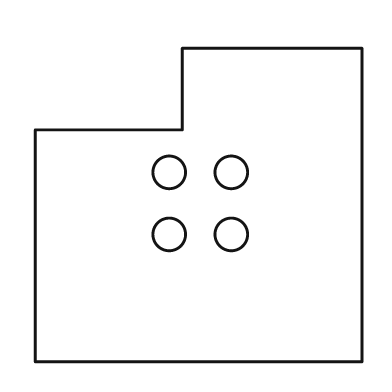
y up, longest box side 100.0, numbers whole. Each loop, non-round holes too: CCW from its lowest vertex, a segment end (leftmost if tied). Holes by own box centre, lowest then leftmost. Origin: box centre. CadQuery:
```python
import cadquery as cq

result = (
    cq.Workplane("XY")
    .moveTo(-50.0, -48.0)
    .lineTo(50.0, -48.0)
    .lineTo(50.0, 48.0)
    .lineTo(-5.0, 48.0)
    .lineTo(-5.0, 23.0)
    .lineTo(-50.0, 23.0)
    .close()
    .moveTo(-9.0, -9.0)
    .circle(5.0)
    .moveTo(10.0, -9.0)
    .circle(5.0)
    .moveTo(-9.0, 10.0)
    .circle(5.0)
    .moveTo(10.0, 10.0)
    .circle(5.0)
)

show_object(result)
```